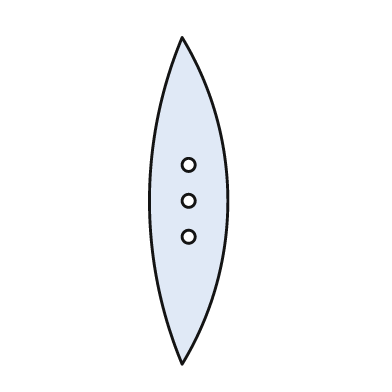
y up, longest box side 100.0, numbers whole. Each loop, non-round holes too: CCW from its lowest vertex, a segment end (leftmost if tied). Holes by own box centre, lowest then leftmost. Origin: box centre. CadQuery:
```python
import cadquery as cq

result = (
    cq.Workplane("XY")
    .moveTo(-2.0, -50.0)
    .threePointArc((12.0, 0.0), (-2.0, 50.0))
    .threePointArc((-12.0, 0.0), (-2.0, -50.0))
    .close()
    .moveTo(0.0, -11.0)
    .circle(2.0)
    .moveTo(0.0, 0.0)
    .circle(2.0)
    .moveTo(0.0, 11.0)
    .circle(2.0)
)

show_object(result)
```